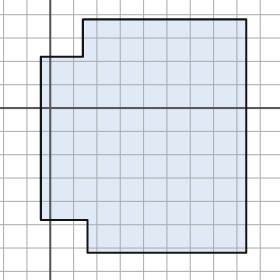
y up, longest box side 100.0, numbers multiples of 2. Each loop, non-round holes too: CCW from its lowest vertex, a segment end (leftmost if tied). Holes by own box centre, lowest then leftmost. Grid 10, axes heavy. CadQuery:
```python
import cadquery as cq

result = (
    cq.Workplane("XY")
    .moveTo(16.0, -62.0)
    .lineTo(84.0, -62.0)
    .lineTo(84.0, 38.0)
    .lineTo(14.0, 38.0)
    .lineTo(14.0, 22.0)
    .lineTo(-4.0, 22.0)
    .lineTo(-4.0, -48.0)
    .lineTo(16.0, -48.0)
    .close()
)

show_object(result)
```